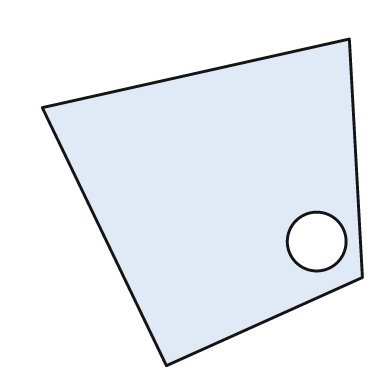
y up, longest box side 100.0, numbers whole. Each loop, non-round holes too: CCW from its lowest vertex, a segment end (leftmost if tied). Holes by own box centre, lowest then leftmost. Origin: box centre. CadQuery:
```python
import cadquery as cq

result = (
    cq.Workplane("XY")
    .moveTo(-11.0, -50.0)
    .lineTo(49.0, -23.0)
    .lineTo(45.0, 50.0)
    .lineTo(-49.0, 29.0)
    .close()
    .moveTo(35.0, -12.0)
    .circle(9.0)
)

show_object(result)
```